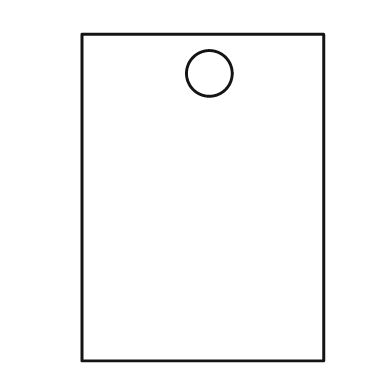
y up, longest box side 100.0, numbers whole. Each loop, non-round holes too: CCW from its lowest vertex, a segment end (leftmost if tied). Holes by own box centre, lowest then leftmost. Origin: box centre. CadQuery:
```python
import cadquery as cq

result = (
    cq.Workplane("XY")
    .moveTo(-37.0, -50.0)
    .lineTo(37.0, -50.0)
    .lineTo(37.0, 50.0)
    .lineTo(-37.0, 50.0)
    .close()
    .moveTo(2.0, 38.0)
    .circle(7.0)
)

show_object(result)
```